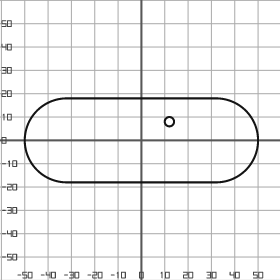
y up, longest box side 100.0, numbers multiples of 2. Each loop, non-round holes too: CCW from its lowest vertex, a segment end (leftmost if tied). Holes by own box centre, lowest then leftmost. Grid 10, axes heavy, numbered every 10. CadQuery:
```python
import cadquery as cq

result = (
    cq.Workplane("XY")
    .moveTo(-32.0, -18.0)
    .lineTo(32.0, -18.0)
    .threePointArc((50.0, 0.0), (32.0, 18.0))
    .lineTo(-32.0, 18.0)
    .threePointArc((-50.0, 0.0), (-32.0, -18.0))
    .close()
    .moveTo(12.0, 8.0)
    .circle(2.0)
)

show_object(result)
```